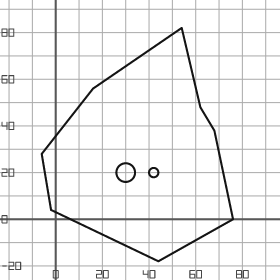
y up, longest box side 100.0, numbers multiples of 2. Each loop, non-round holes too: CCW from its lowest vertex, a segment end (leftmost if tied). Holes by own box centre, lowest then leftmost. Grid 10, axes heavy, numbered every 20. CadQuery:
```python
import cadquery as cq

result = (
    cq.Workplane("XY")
    .moveTo(44.0, -18.0)
    .lineTo(76.0, 0.0)
    .lineTo(68.0, 38.0)
    .lineTo(62.0, 48.0)
    .lineTo(54.0, 82.0)
    .lineTo(16.0, 56.0)
    .lineTo(-6.0, 28.0)
    .lineTo(-2.0, 4.0)
    .close()
    .moveTo(30.0, 20.0)
    .circle(4.0)
    .moveTo(42.0, 20.0)
    .circle(2.0)
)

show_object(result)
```